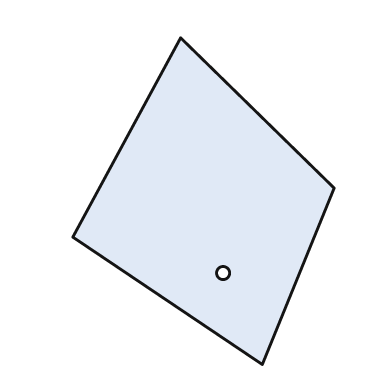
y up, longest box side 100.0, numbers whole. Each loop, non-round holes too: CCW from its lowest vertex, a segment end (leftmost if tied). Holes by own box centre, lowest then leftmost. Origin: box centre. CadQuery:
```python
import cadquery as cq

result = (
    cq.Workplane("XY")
    .moveTo(18.0, -50.0)
    .lineTo(40.0, 4.0)
    .lineTo(-7.0, 50.0)
    .lineTo(-40.0, -11.0)
    .close()
    .moveTo(6.0, -22.0)
    .circle(2.0)
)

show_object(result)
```